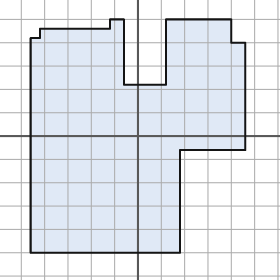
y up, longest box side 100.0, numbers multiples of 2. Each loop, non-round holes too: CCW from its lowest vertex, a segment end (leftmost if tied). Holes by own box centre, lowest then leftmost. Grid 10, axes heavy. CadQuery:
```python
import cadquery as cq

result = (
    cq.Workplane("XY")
    .moveTo(-46.0, -50.0)
    .lineTo(18.0, -50.0)
    .lineTo(18.0, -6.0)
    .lineTo(46.0, -6.0)
    .lineTo(46.0, 40.0)
    .lineTo(40.0, 40.0)
    .lineTo(40.0, 50.0)
    .lineTo(12.0, 50.0)
    .lineTo(12.0, 22.0)
    .lineTo(-6.0, 22.0)
    .lineTo(-6.0, 50.0)
    .lineTo(-12.0, 50.0)
    .lineTo(-12.0, 46.0)
    .lineTo(-42.0, 46.0)
    .lineTo(-42.0, 42.0)
    .lineTo(-46.0, 42.0)
    .close()
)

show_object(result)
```